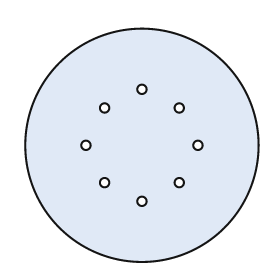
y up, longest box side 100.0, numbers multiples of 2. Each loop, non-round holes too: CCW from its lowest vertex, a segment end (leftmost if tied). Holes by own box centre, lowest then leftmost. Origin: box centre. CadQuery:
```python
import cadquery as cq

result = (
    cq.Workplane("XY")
    .moveTo(0.0, 0.0)
    .circle(50.0)
    .moveTo(0.0, -24.0)
    .circle(2.0)
    .moveTo(-16.0, -16.0)
    .circle(2.0)
    .moveTo(16.0, -16.0)
    .circle(2.0)
    .moveTo(-24.0, 0.0)
    .circle(2.0)
    .moveTo(24.0, 0.0)
    .circle(2.0)
    .moveTo(-16.0, 16.0)
    .circle(2.0)
    .moveTo(16.0, 16.0)
    .circle(2.0)
    .moveTo(0.0, 24.0)
    .circle(2.0)
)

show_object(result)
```